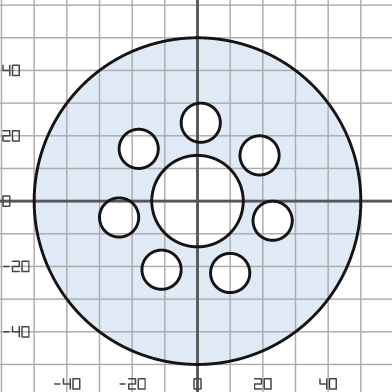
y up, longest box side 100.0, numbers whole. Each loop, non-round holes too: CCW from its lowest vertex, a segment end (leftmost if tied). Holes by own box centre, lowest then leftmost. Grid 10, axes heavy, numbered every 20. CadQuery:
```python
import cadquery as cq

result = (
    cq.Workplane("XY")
    .moveTo(0.0, 0.0)
    .circle(50.0)
    .moveTo(10.0, -22.0)
    .circle(6.0)
    .moveTo(-11.0, -21.0)
    .circle(6.0)
    .moveTo(23.0, -6.0)
    .circle(6.0)
    .moveTo(-24.0, -5.0)
    .circle(6.0)
    .moveTo(0.0, 0.0)
    .circle(14.0)
    .moveTo(19.0, 14.0)
    .circle(6.0)
    .moveTo(-18.0, 16.0)
    .circle(6.0)
    .moveTo(1.0, 24.0)
    .circle(6.0)
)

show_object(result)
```